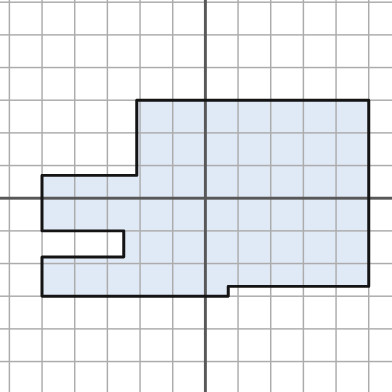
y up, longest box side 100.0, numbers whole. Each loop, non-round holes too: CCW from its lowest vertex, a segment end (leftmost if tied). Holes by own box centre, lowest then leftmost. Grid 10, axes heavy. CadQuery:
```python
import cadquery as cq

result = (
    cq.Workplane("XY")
    .moveTo(-50.0, -30.0)
    .lineTo(7.0, -30.0)
    .lineTo(7.0, -27.0)
    .lineTo(50.0, -27.0)
    .lineTo(50.0, 30.0)
    .lineTo(-21.0, 30.0)
    .lineTo(-21.0, 7.0)
    .lineTo(-50.0, 7.0)
    .lineTo(-50.0, -10.0)
    .lineTo(-25.0, -10.0)
    .lineTo(-25.0, -18.0)
    .lineTo(-50.0, -18.0)
    .close()
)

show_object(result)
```